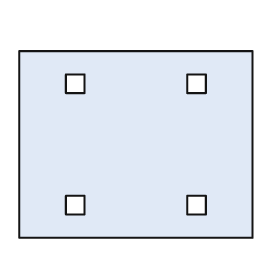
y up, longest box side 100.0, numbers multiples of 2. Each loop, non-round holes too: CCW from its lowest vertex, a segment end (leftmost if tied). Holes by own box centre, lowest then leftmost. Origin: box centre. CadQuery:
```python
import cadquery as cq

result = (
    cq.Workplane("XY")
    .moveTo(-50.0, -40.0)
    .lineTo(50.0, -40.0)
    .lineTo(50.0, 40.0)
    .lineTo(-50.0, 40.0)
    .close()
    .moveTo(-30.0, -30.0)
    .lineTo(-22.0, -30.0)
    .lineTo(-22.0, -22.0)
    .lineTo(-30.0, -22.0)
    .close()
    .moveTo(22.0, -30.0)
    .lineTo(30.0, -30.0)
    .lineTo(30.0, -22.0)
    .lineTo(22.0, -22.0)
    .close()
    .moveTo(-30.0, 22.0)
    .lineTo(-22.0, 22.0)
    .lineTo(-22.0, 30.0)
    .lineTo(-30.0, 30.0)
    .close()
    .moveTo(22.0, 22.0)
    .lineTo(30.0, 22.0)
    .lineTo(30.0, 30.0)
    .lineTo(22.0, 30.0)
    .close()
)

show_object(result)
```